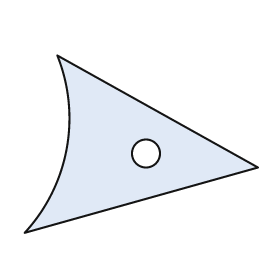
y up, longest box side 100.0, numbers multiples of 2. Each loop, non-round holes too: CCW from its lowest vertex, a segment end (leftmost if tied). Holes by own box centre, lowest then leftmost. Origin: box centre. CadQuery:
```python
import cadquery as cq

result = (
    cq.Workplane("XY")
    .moveTo(-50.0, -38.0)
    .lineTo(50.0, -10.0)
    .lineTo(-36.0, 38.0)
    .threePointArc((-32.0, -2.0), (-50.0, -38.0))
    .close()
    .moveTo(2.0, -4.0)
    .circle(6.0)
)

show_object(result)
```